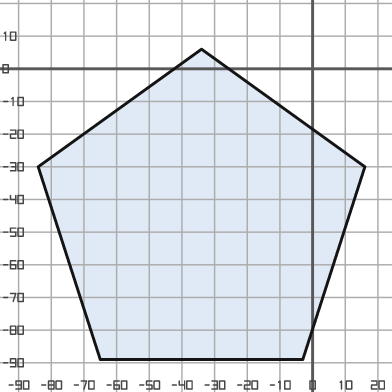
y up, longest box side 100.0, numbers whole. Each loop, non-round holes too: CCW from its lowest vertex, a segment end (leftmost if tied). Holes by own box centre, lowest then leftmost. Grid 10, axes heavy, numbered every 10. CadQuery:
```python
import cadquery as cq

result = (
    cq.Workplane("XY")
    .moveTo(-65.0, -89.0)
    .lineTo(-3.0, -89.0)
    .lineTo(16.0, -30.0)
    .lineTo(-34.0, 6.0)
    .lineTo(-84.0, -30.0)
    .close()
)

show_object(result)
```